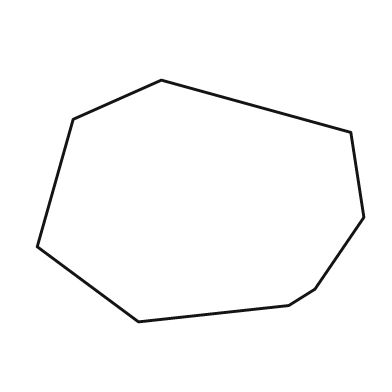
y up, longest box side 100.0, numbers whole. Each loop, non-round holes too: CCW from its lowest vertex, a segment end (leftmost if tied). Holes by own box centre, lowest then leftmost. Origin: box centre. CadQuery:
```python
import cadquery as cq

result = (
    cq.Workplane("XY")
    .moveTo(-19.0, -37.0)
    .lineTo(27.0, -32.0)
    .lineTo(35.0, -27.0)
    .lineTo(50.0, -5.0)
    .lineTo(46.0, 21.0)
    .lineTo(-12.0, 37.0)
    .lineTo(-39.0, 25.0)
    .lineTo(-50.0, -14.0)
    .close()
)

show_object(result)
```